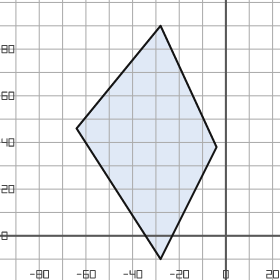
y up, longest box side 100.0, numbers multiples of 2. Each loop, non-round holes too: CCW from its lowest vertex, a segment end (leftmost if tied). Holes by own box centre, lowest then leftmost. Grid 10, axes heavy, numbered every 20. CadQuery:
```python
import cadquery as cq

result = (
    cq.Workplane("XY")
    .moveTo(-28.0, -10.0)
    .lineTo(-4.0, 38.0)
    .lineTo(-28.0, 90.0)
    .lineTo(-64.0, 46.0)
    .close()
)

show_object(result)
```